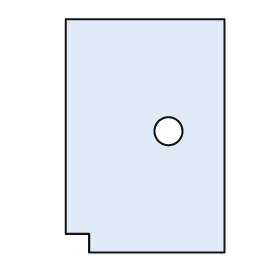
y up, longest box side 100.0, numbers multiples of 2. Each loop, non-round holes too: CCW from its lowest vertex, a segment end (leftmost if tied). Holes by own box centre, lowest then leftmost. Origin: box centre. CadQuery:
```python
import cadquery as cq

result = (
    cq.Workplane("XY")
    .moveTo(-24.0, -50.0)
    .lineTo(34.0, -50.0)
    .lineTo(34.0, 50.0)
    .lineTo(-34.0, 50.0)
    .lineTo(-34.0, -42.0)
    .lineTo(-24.0, -42.0)
    .close()
    .moveTo(10.0, 2.0)
    .circle(6.0)
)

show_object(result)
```